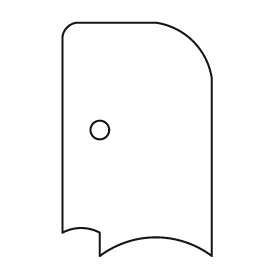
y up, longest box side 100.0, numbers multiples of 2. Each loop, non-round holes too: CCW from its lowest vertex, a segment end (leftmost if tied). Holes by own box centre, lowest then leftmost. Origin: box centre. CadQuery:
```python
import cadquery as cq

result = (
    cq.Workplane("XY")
    .moveTo(-16.0, -50.0)
    .threePointArc((8.0, -42.0), (32.0, -50.0))
    .lineTo(32.0, 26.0)
    .threePointArc((24.0, 42.0), (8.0, 50.0))
    .lineTo(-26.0, 50.0)
    .threePointArc((-30.0, 48.0), (-32.0, 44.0))
    .lineTo(-32.0, -40.0)
    .threePointArc((-24.0, -38.0), (-16.0, -40.0))
    .close()
    .moveTo(-16.0, 4.0)
    .circle(4.0)
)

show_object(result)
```